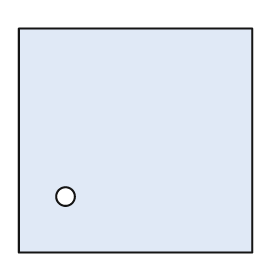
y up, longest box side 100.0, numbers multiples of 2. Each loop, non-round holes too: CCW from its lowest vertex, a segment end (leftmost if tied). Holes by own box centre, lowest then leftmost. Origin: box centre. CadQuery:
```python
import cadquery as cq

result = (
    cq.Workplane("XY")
    .moveTo(-50.0, -48.0)
    .lineTo(50.0, -48.0)
    .lineTo(50.0, 48.0)
    .lineTo(-50.0, 48.0)
    .close()
    .moveTo(-30.0, -24.0)
    .circle(4.0)
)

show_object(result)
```